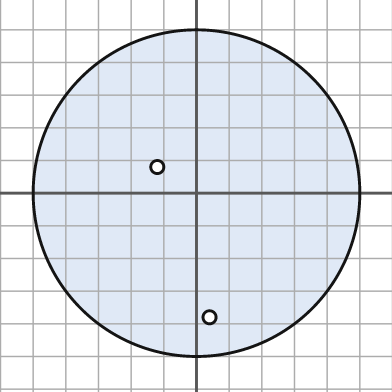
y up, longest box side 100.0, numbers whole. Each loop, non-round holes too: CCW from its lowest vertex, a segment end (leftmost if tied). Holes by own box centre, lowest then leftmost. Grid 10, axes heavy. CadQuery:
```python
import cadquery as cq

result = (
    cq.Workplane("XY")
    .moveTo(0.0, 0.0)
    .circle(50.0)
    .moveTo(4.0, -38.0)
    .circle(2.0)
    .moveTo(-12.0, 8.0)
    .circle(2.0)
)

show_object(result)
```